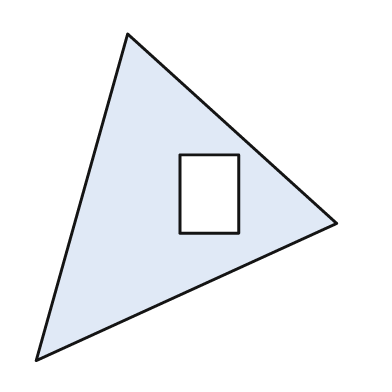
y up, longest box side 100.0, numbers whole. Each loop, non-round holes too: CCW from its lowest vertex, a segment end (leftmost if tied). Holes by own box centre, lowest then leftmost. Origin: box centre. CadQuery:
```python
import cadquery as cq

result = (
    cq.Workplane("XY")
    .moveTo(-46.0, -50.0)
    .lineTo(46.0, -8.0)
    .lineTo(-18.0, 50.0)
    .close()
    .moveTo(-2.0, -11.0)
    .lineTo(16.0, -11.0)
    .lineTo(16.0, 13.0)
    .lineTo(-2.0, 13.0)
    .close()
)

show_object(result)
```